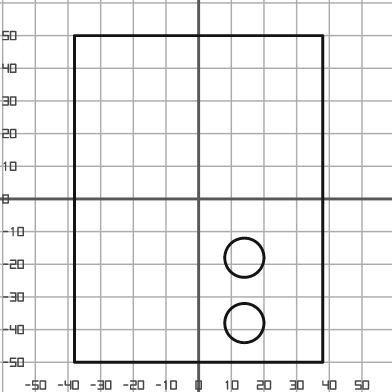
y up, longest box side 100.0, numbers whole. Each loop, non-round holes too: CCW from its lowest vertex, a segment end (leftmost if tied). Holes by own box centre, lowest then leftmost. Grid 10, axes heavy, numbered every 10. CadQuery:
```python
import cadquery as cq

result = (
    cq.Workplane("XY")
    .moveTo(-38.0, -50.0)
    .lineTo(38.0, -50.0)
    .lineTo(38.0, 50.0)
    .lineTo(-38.0, 50.0)
    .close()
    .moveTo(14.0, -38.0)
    .circle(6.0)
    .moveTo(14.0, -18.0)
    .circle(6.0)
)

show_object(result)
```